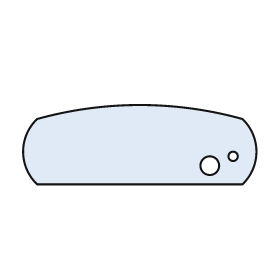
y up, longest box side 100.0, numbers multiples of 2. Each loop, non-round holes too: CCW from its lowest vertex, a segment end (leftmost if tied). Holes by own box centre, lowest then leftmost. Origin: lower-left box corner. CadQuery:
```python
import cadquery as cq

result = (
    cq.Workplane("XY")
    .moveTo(6.0, 0.0)
    .lineTo(94.0, 0.0)
    .threePointArc((100.0, 14.0), (94.0, 28.0))
    .threePointArc((50.0, 34.0), (6.0, 28.0))
    .threePointArc((0.0, 14.0), (6.0, 0.0))
    .close()
    .moveTo(80.0, 8.0)
    .circle(4.0)
    .moveTo(90.0, 12.0)
    .circle(2.0)
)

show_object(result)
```